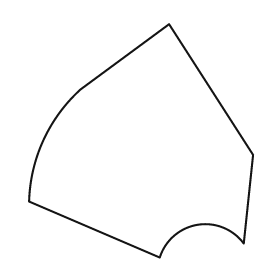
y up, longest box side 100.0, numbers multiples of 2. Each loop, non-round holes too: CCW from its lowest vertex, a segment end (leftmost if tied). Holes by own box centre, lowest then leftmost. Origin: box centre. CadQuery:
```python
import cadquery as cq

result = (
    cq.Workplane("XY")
    .moveTo(8.0, -50.0)
    .threePointArc((24.0, -36.0), (44.0, -44.0))
    .lineTo(48.0, -6.0)
    .lineTo(12.0, 50.0)
    .lineTo(-26.0, 22.0)
    .threePointArc((-42.0, 0.0), (-48.0, -26.0))
    .close()
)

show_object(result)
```